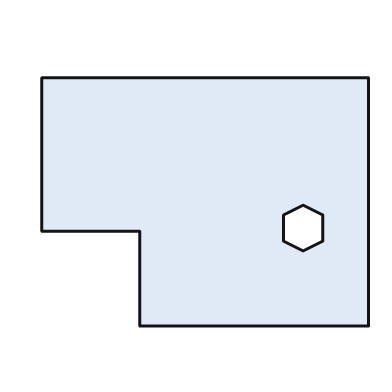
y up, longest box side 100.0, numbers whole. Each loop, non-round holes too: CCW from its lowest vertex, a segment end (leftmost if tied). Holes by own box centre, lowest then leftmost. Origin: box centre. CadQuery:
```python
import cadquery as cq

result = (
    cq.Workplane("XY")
    .moveTo(-20.0, -38.0)
    .lineTo(50.0, -38.0)
    .lineTo(50.0, 38.0)
    .lineTo(-50.0, 38.0)
    .lineTo(-50.0, -9.0)
    .lineTo(-20.0, -9.0)
    .close()
    .moveTo(30.0, -15.0)
    .lineTo(36.0, -12.0)
    .lineTo(36.0, -4.0)
    .lineTo(30.0, -1.0)
    .lineTo(24.0, -4.0)
    .lineTo(24.0, -12.0)
    .close()
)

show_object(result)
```